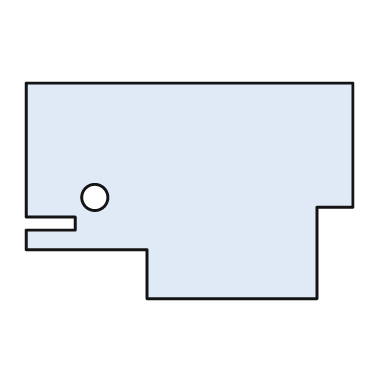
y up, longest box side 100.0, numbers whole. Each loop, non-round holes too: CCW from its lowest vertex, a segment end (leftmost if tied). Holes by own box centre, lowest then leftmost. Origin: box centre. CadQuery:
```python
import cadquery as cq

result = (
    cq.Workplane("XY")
    .moveTo(-13.0, -33.0)
    .lineTo(39.0, -33.0)
    .lineTo(39.0, -5.0)
    .lineTo(50.0, -5.0)
    .lineTo(50.0, 33.0)
    .lineTo(-50.0, 33.0)
    .lineTo(-50.0, -8.0)
    .lineTo(-35.0, -8.0)
    .lineTo(-35.0, -12.0)
    .lineTo(-50.0, -12.0)
    .lineTo(-50.0, -18.0)
    .lineTo(-13.0, -18.0)
    .close()
    .moveTo(-29.0, -2.0)
    .circle(4.0)
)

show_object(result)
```